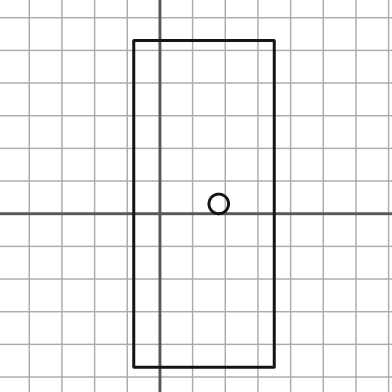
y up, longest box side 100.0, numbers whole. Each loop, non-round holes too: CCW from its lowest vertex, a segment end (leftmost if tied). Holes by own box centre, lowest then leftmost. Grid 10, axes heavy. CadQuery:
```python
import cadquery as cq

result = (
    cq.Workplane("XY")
    .moveTo(-8.0, -47.0)
    .lineTo(35.0, -47.0)
    .lineTo(35.0, 53.0)
    .lineTo(-8.0, 53.0)
    .close()
    .moveTo(18.0, 3.0)
    .circle(3.0)
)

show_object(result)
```